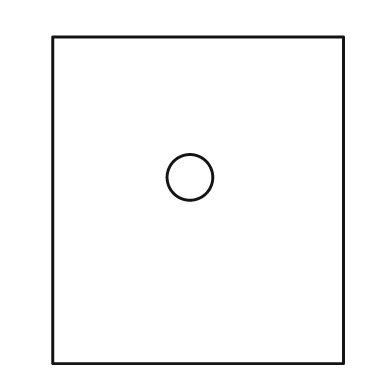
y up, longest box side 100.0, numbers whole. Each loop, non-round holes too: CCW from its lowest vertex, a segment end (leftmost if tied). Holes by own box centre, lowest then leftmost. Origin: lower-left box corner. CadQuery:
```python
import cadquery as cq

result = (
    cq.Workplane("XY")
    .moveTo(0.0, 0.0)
    .lineTo(89.0, 0.0)
    .lineTo(89.0, 100.0)
    .lineTo(0.0, 100.0)
    .close()
    .moveTo(42.0, 57.0)
    .circle(7.0)
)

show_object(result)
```